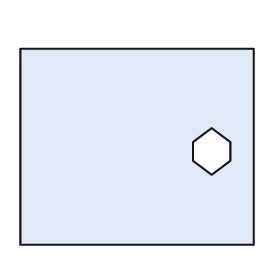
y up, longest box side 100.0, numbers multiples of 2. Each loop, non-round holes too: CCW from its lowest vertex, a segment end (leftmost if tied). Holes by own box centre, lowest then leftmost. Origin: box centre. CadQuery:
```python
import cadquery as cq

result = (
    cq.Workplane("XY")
    .moveTo(-50.0, -42.0)
    .lineTo(50.0, -42.0)
    .lineTo(50.0, 42.0)
    .lineTo(-50.0, 42.0)
    .close()
    .moveTo(32.0, -12.0)
    .lineTo(40.0, -6.0)
    .lineTo(40.0, 2.0)
    .lineTo(32.0, 8.0)
    .lineTo(24.0, 2.0)
    .lineTo(24.0, -6.0)
    .close()
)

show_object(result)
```